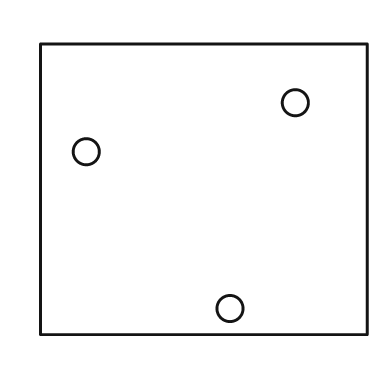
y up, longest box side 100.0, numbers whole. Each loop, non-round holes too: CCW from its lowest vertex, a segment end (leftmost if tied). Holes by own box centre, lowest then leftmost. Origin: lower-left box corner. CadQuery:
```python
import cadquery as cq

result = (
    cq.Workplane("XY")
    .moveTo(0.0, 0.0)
    .lineTo(100.0, 0.0)
    .lineTo(100.0, 89.0)
    .lineTo(0.0, 89.0)
    .close()
    .moveTo(58.0, 8.0)
    .circle(4.0)
    .moveTo(14.0, 56.0)
    .circle(4.0)
    .moveTo(78.0, 71.0)
    .circle(4.0)
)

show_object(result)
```